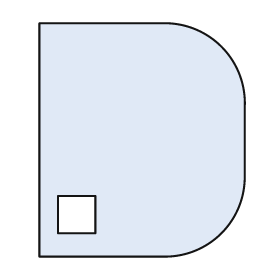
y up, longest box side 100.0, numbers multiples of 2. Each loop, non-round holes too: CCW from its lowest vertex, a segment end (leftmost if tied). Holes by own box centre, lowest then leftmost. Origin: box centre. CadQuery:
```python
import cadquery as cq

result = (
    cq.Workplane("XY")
    .moveTo(-44.0, -50.0)
    .lineTo(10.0, -50.0)
    .threePointArc((34.0, -40.0), (44.0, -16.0))
    .lineTo(44.0, 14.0)
    .threePointArc((34.0, 40.0), (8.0, 50.0))
    .lineTo(-44.0, 50.0)
    .close()
    .moveTo(-36.0, -40.0)
    .lineTo(-20.0, -40.0)
    .lineTo(-20.0, -24.0)
    .lineTo(-36.0, -24.0)
    .close()
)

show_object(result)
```